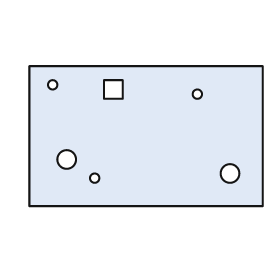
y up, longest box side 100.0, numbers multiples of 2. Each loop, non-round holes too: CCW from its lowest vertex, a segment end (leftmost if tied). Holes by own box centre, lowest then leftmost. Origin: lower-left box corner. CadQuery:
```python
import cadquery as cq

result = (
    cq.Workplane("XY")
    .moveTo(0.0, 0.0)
    .lineTo(100.0, 0.0)
    .lineTo(100.0, 60.0)
    .lineTo(0.0, 60.0)
    .close()
    .moveTo(28.0, 12.0)
    .circle(2.0)
    .moveTo(86.0, 14.0)
    .circle(4.0)
    .moveTo(16.0, 20.0)
    .circle(4.0)
    .moveTo(72.0, 48.0)
    .circle(2.0)
    .moveTo(32.0, 46.0)
    .lineTo(40.0, 46.0)
    .lineTo(40.0, 54.0)
    .lineTo(32.0, 54.0)
    .close()
    .moveTo(10.0, 52.0)
    .circle(2.0)
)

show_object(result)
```